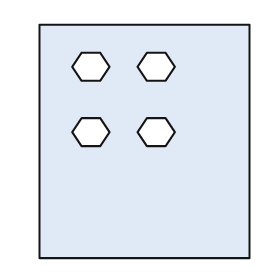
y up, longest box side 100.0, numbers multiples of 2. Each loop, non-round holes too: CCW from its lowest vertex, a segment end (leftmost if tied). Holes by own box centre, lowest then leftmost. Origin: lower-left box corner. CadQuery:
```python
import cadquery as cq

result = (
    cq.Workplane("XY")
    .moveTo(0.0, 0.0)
    .lineTo(90.0, 0.0)
    .lineTo(90.0, 100.0)
    .lineTo(0.0, 100.0)
    .close()
    .moveTo(18.0, 48.0)
    .lineTo(26.0, 48.0)
    .lineTo(30.0, 54.0)
    .lineTo(26.0, 60.0)
    .lineTo(18.0, 60.0)
    .lineTo(14.0, 54.0)
    .close()
    .moveTo(46.0, 48.0)
    .lineTo(54.0, 48.0)
    .lineTo(58.0, 54.0)
    .lineTo(54.0, 60.0)
    .lineTo(46.0, 60.0)
    .lineTo(42.0, 54.0)
    .close()
    .moveTo(18.0, 76.0)
    .lineTo(26.0, 76.0)
    .lineTo(30.0, 82.0)
    .lineTo(26.0, 88.0)
    .lineTo(18.0, 88.0)
    .lineTo(14.0, 82.0)
    .close()
    .moveTo(46.0, 76.0)
    .lineTo(54.0, 76.0)
    .lineTo(58.0, 82.0)
    .lineTo(54.0, 88.0)
    .lineTo(46.0, 88.0)
    .lineTo(42.0, 82.0)
    .close()
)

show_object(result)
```